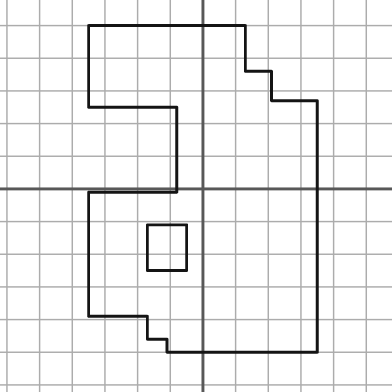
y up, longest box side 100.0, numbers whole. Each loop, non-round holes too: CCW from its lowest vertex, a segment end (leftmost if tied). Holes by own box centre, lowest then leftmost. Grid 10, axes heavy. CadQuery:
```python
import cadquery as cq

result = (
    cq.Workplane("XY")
    .moveTo(-11.0, -50.0)
    .lineTo(35.0, -50.0)
    .lineTo(35.0, 27.0)
    .lineTo(21.0, 27.0)
    .lineTo(21.0, 36.0)
    .lineTo(13.0, 36.0)
    .lineTo(13.0, 50.0)
    .lineTo(-35.0, 50.0)
    .lineTo(-35.0, 25.0)
    .lineTo(-8.0, 25.0)
    .lineTo(-8.0, -1.0)
    .lineTo(-35.0, -1.0)
    .lineTo(-35.0, -39.0)
    .lineTo(-17.0, -39.0)
    .lineTo(-17.0, -46.0)
    .lineTo(-11.0, -46.0)
    .close()
    .moveTo(-17.0, -25.0)
    .lineTo(-5.0, -25.0)
    .lineTo(-5.0, -11.0)
    .lineTo(-17.0, -11.0)
    .close()
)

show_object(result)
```